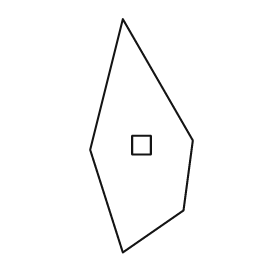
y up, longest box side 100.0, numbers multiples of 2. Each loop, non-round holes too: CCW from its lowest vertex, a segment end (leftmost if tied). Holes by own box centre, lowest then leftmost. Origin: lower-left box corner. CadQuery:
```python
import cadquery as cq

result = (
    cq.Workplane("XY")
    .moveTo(14.0, 0.0)
    .lineTo(40.0, 18.0)
    .lineTo(44.0, 48.0)
    .lineTo(14.0, 100.0)
    .lineTo(0.0, 44.0)
    .close()
    .moveTo(18.0, 42.0)
    .lineTo(26.0, 42.0)
    .lineTo(26.0, 50.0)
    .lineTo(18.0, 50.0)
    .close()
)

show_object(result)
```